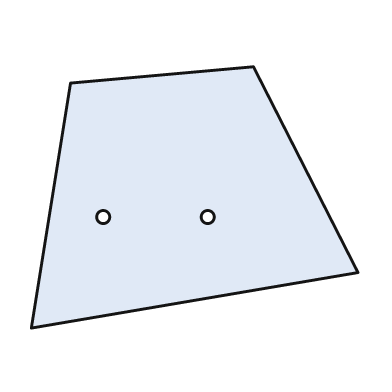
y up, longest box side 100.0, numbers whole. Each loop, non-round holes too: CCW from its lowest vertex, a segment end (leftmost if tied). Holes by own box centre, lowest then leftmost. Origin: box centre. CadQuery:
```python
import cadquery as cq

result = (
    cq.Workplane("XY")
    .moveTo(-50.0, -40.0)
    .lineTo(50.0, -23.0)
    .lineTo(18.0, 40.0)
    .lineTo(-38.0, 35.0)
    .close()
    .moveTo(-28.0, -6.0)
    .circle(2.0)
    .moveTo(4.0, -6.0)
    .circle(2.0)
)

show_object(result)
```